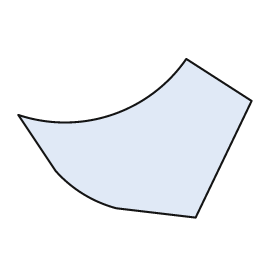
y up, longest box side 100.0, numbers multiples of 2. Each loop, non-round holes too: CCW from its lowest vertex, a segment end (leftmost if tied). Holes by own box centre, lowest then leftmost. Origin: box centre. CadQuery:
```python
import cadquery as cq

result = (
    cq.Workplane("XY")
    .moveTo(26.0, -34.0)
    .lineTo(50.0, 16.0)
    .lineTo(22.0, 34.0)
    .threePointArc((-10.0, 10.0), (-50.0, 10.0))
    .lineTo(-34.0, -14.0)
    .threePointArc((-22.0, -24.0), (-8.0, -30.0))
    .close()
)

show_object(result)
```